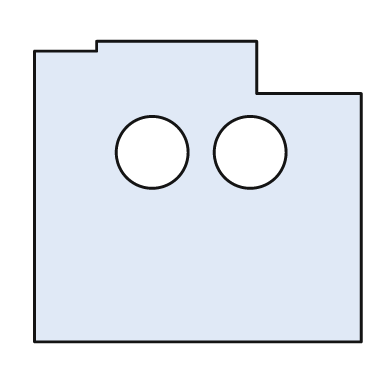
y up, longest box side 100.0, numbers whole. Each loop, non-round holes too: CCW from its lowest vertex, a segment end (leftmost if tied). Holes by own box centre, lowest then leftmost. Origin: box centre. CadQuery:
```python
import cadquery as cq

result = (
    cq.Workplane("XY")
    .moveTo(-50.0, -46.0)
    .lineTo(50.0, -46.0)
    .lineTo(50.0, 30.0)
    .lineTo(18.0, 30.0)
    .lineTo(18.0, 46.0)
    .lineTo(-31.0, 46.0)
    .lineTo(-31.0, 43.0)
    .lineTo(-50.0, 43.0)
    .close()
    .moveTo(-14.0, 12.0)
    .circle(11.0)
    .moveTo(16.0, 12.0)
    .circle(11.0)
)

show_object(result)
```